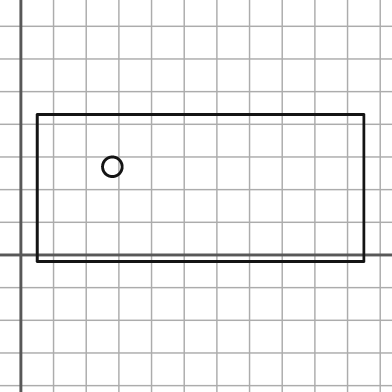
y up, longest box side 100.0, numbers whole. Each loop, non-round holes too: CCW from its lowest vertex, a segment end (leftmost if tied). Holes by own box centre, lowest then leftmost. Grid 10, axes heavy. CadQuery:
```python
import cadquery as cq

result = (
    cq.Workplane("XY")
    .moveTo(5.0, -2.0)
    .lineTo(105.0, -2.0)
    .lineTo(105.0, 43.0)
    .lineTo(5.0, 43.0)
    .close()
    .moveTo(28.0, 27.0)
    .circle(3.0)
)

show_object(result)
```